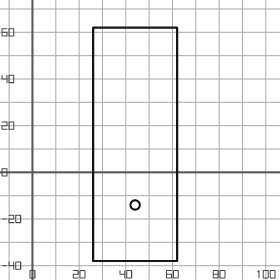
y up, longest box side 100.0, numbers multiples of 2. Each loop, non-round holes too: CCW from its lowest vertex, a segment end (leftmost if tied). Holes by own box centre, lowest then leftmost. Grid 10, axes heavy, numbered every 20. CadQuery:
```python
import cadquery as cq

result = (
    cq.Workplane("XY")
    .moveTo(26.0, -38.0)
    .lineTo(62.0, -38.0)
    .lineTo(62.0, 62.0)
    .lineTo(26.0, 62.0)
    .close()
    .moveTo(44.0, -14.0)
    .circle(2.0)
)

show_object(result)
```